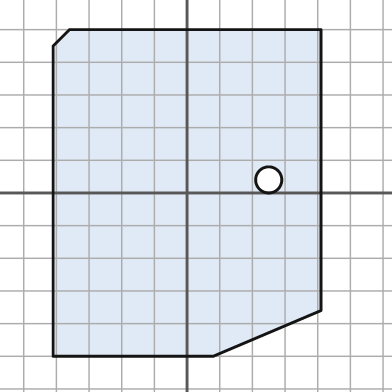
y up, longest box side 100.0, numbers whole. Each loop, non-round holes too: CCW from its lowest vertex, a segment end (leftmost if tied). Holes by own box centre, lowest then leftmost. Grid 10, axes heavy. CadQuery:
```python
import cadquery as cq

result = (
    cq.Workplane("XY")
    .moveTo(-41.0, -50.0)
    .lineTo(8.0, -50.0)
    .lineTo(41.0, -36.0)
    .lineTo(41.0, 50.0)
    .lineTo(-36.0, 50.0)
    .lineTo(-41.0, 45.0)
    .close()
    .moveTo(25.0, 4.0)
    .circle(4.0)
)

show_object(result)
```